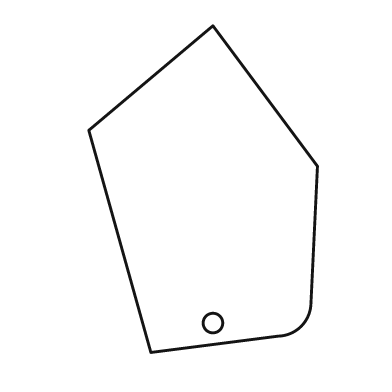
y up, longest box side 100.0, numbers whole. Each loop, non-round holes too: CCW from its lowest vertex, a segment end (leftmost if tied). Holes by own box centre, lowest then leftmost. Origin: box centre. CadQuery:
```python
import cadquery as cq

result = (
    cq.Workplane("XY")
    .moveTo(-16.0, -50.0)
    .lineTo(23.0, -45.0)
    .threePointArc((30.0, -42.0), (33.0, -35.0))
    .lineTo(35.0, 7.0)
    .lineTo(3.0, 50.0)
    .lineTo(-35.0, 18.0)
    .close()
    .moveTo(3.0, -41.0)
    .circle(3.0)
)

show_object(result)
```